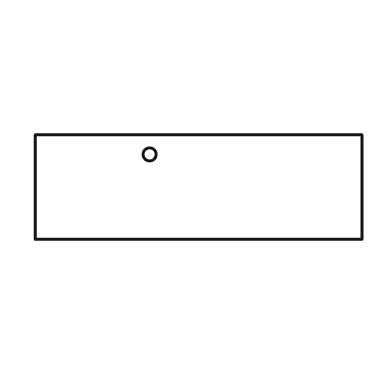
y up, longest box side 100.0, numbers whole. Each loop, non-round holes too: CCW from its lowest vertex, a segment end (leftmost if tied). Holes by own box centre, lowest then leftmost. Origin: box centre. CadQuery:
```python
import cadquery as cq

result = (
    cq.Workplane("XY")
    .moveTo(-50.0, -16.0)
    .lineTo(50.0, -16.0)
    .lineTo(50.0, 16.0)
    .lineTo(-50.0, 16.0)
    .close()
    .moveTo(-15.0, 10.0)
    .circle(2.0)
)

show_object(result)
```